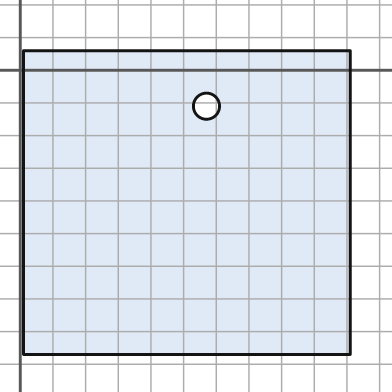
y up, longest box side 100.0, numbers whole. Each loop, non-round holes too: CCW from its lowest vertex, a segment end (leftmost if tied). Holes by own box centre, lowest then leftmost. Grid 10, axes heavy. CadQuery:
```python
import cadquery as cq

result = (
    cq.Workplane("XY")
    .moveTo(1.0, -87.0)
    .lineTo(101.0, -87.0)
    .lineTo(101.0, 6.0)
    .lineTo(1.0, 6.0)
    .close()
    .moveTo(57.0, -11.0)
    .circle(4.0)
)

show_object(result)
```